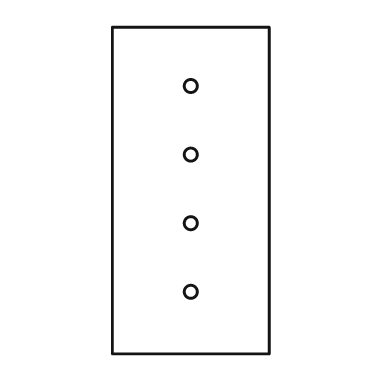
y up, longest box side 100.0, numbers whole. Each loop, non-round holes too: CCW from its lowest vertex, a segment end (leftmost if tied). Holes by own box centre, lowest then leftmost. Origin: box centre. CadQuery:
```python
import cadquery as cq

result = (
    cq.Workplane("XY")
    .moveTo(-24.0, -50.0)
    .lineTo(24.0, -50.0)
    .lineTo(24.0, 50.0)
    .lineTo(-24.0, 50.0)
    .close()
    .moveTo(0.0, -31.0)
    .circle(2.0)
    .moveTo(0.0, -10.0)
    .circle(2.0)
    .moveTo(0.0, 11.0)
    .circle(2.0)
    .moveTo(0.0, 32.0)
    .circle(2.0)
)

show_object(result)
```